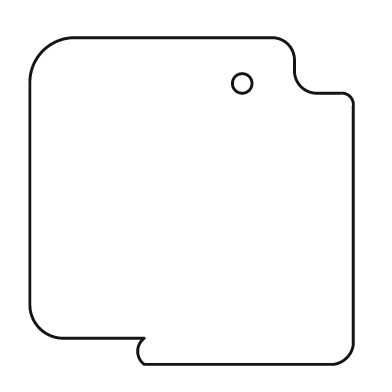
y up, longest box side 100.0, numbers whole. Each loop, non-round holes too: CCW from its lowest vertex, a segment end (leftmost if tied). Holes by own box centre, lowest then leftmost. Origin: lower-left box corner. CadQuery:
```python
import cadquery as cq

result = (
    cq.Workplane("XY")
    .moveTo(35.0, 0.0)
    .lineTo(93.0, 0.0)
    .threePointArc((97.0, 2.0), (99.0, 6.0))
    .lineTo(99.0, 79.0)
    .threePointArc((98.0, 82.0), (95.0, 83.0))
    .lineTo(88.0, 83.0)
    .threePointArc((83.0, 85.0), (81.0, 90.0))
    .lineTo(81.0, 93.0)
    .threePointArc((79.0, 98.0), (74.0, 100.0))
    .lineTo(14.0, 100.0)
    .threePointArc((4.0, 96.0), (0.0, 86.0))
    .lineTo(0.0, 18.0)
    .threePointArc((3.0, 11.0), (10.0, 8.0))
    .lineTo(35.0, 8.0)
    .threePointArc((33.0, 4.0), (35.0, 0.0))
    .close()
    .moveTo(65.0, 86.0)
    .circle(3.0)
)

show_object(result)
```